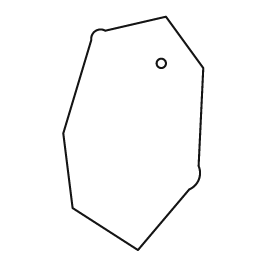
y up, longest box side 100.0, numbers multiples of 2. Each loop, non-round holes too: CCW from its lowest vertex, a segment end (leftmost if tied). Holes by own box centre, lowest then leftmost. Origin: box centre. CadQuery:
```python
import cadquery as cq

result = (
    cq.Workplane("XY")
    .moveTo(2.0, -50.0)
    .lineTo(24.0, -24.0)
    .threePointArc((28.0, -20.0), (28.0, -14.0))
    .lineTo(30.0, 28.0)
    .lineTo(14.0, 50.0)
    .lineTo(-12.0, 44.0)
    .threePointArc((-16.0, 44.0), (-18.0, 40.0))
    .lineTo(-30.0, 0.0)
    .lineTo(-26.0, -32.0)
    .close()
    .moveTo(12.0, 30.0)
    .circle(2.0)
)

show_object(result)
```